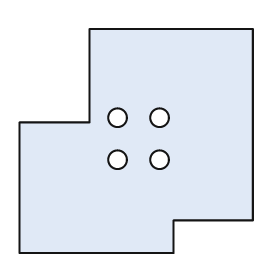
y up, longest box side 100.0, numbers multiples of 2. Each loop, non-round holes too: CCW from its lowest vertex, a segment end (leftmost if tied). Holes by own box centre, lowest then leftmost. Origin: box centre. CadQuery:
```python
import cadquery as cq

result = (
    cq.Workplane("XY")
    .moveTo(-50.0, -48.0)
    .lineTo(16.0, -48.0)
    .lineTo(16.0, -34.0)
    .lineTo(50.0, -34.0)
    .lineTo(50.0, 48.0)
    .lineTo(-20.0, 48.0)
    .lineTo(-20.0, 8.0)
    .lineTo(-50.0, 8.0)
    .close()
    .moveTo(-8.0, -8.0)
    .circle(4.0)
    .moveTo(10.0, -8.0)
    .circle(4.0)
    .moveTo(-8.0, 10.0)
    .circle(4.0)
    .moveTo(10.0, 10.0)
    .circle(4.0)
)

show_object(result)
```